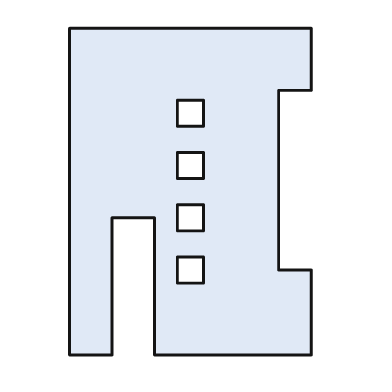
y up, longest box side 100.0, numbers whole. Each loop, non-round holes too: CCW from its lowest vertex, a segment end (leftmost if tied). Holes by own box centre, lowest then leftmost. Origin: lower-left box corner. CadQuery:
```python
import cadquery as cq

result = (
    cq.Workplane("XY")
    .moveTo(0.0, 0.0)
    .lineTo(13.0, 0.0)
    .lineTo(13.0, 42.0)
    .lineTo(26.0, 42.0)
    .lineTo(26.0, 0.0)
    .lineTo(74.0, 0.0)
    .lineTo(74.0, 26.0)
    .lineTo(64.0, 26.0)
    .lineTo(64.0, 81.0)
    .lineTo(74.0, 81.0)
    .lineTo(74.0, 100.0)
    .lineTo(0.0, 100.0)
    .close()
    .moveTo(33.0, 22.0)
    .lineTo(41.0, 22.0)
    .lineTo(41.0, 30.0)
    .lineTo(33.0, 30.0)
    .close()
    .moveTo(33.0, 38.0)
    .lineTo(41.0, 38.0)
    .lineTo(41.0, 46.0)
    .lineTo(33.0, 46.0)
    .close()
    .moveTo(33.0, 54.0)
    .lineTo(41.0, 54.0)
    .lineTo(41.0, 62.0)
    .lineTo(33.0, 62.0)
    .close()
    .moveTo(33.0, 70.0)
    .lineTo(41.0, 70.0)
    .lineTo(41.0, 78.0)
    .lineTo(33.0, 78.0)
    .close()
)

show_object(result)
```